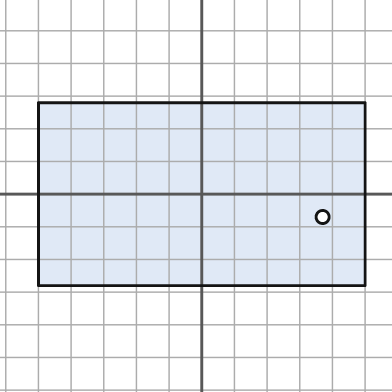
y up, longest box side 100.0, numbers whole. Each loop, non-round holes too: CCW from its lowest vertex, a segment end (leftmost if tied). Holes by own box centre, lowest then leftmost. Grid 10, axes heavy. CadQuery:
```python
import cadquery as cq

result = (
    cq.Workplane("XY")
    .moveTo(-50.0, -28.0)
    .lineTo(50.0, -28.0)
    .lineTo(50.0, 28.0)
    .lineTo(-50.0, 28.0)
    .close()
    .moveTo(37.0, -7.0)
    .circle(2.0)
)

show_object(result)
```